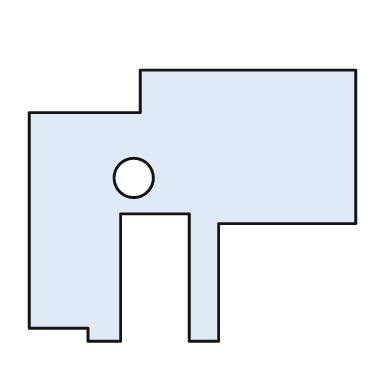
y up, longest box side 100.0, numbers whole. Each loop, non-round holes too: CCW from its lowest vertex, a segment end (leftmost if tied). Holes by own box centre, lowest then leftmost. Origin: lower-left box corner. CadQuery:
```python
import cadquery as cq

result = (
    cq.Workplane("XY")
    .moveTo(18.0, 0.0)
    .lineTo(28.0, 0.0)
    .lineTo(28.0, 39.0)
    .lineTo(49.0, 39.0)
    .lineTo(49.0, 0.0)
    .lineTo(58.0, 0.0)
    .lineTo(58.0, 36.0)
    .lineTo(100.0, 36.0)
    .lineTo(100.0, 83.0)
    .lineTo(34.0, 83.0)
    .lineTo(34.0, 70.0)
    .lineTo(0.0, 70.0)
    .lineTo(0.0, 4.0)
    .lineTo(18.0, 4.0)
    .close()
    .moveTo(32.0, 50.0)
    .circle(6.0)
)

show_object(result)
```